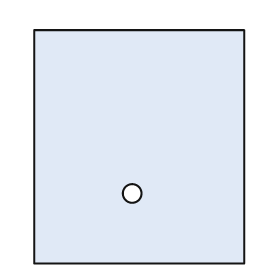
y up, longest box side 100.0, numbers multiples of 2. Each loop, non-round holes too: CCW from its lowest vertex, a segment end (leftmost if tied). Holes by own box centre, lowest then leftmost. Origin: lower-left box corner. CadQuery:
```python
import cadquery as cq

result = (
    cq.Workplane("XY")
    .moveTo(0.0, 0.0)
    .lineTo(90.0, 0.0)
    .lineTo(90.0, 100.0)
    .lineTo(0.0, 100.0)
    .close()
    .moveTo(42.0, 30.0)
    .circle(4.0)
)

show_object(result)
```